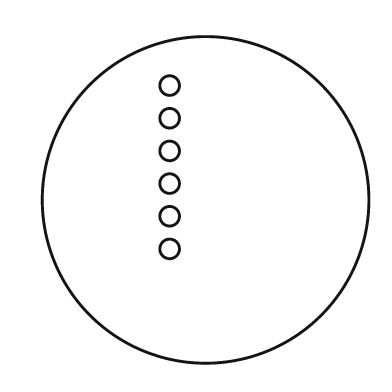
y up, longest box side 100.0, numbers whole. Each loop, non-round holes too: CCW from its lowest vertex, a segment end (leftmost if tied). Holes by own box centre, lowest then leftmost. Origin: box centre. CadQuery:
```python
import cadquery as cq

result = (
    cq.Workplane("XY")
    .moveTo(0.0, 0.0)
    .circle(50.0)
    .moveTo(-11.0, -15.0)
    .circle(3.0)
    .moveTo(-11.0, -5.0)
    .circle(3.0)
    .moveTo(-11.0, 5.0)
    .circle(3.0)
    .moveTo(-11.0, 15.0)
    .circle(3.0)
    .moveTo(-11.0, 25.0)
    .circle(3.0)
    .moveTo(-11.0, 35.0)
    .circle(3.0)
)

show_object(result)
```